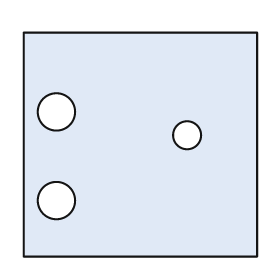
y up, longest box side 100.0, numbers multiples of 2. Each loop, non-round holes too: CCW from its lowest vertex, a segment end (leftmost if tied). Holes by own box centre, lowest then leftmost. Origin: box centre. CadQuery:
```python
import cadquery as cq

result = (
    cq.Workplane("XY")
    .moveTo(-50.0, -48.0)
    .lineTo(50.0, -48.0)
    .lineTo(50.0, 48.0)
    .lineTo(-50.0, 48.0)
    .close()
    .moveTo(-36.0, -24.0)
    .circle(8.0)
    .moveTo(20.0, 4.0)
    .circle(6.0)
    .moveTo(-36.0, 14.0)
    .circle(8.0)
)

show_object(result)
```